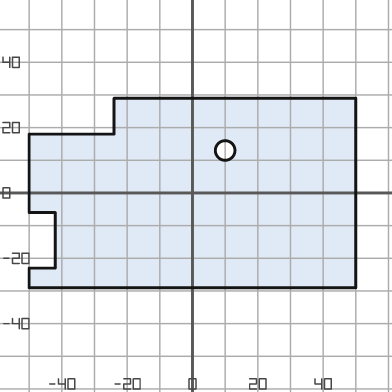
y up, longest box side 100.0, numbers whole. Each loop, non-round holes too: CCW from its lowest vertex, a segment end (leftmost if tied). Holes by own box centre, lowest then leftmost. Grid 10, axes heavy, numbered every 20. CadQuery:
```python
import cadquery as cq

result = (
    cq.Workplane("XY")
    .moveTo(-50.0, -29.0)
    .lineTo(50.0, -29.0)
    .lineTo(50.0, 29.0)
    .lineTo(-24.0, 29.0)
    .lineTo(-24.0, 18.0)
    .lineTo(-50.0, 18.0)
    .lineTo(-50.0, -6.0)
    .lineTo(-42.0, -6.0)
    .lineTo(-42.0, -23.0)
    .lineTo(-50.0, -23.0)
    .close()
    .moveTo(10.0, 13.0)
    .circle(3.0)
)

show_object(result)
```